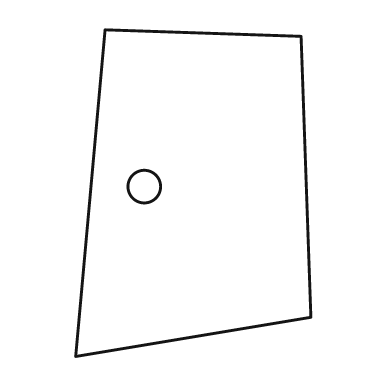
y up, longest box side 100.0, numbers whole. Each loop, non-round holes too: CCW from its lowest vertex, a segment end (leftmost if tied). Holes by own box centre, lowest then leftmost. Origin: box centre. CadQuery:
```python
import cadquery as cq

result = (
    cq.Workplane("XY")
    .moveTo(-36.0, -50.0)
    .lineTo(36.0, -38.0)
    .lineTo(33.0, 48.0)
    .lineTo(-27.0, 50.0)
    .close()
    .moveTo(-15.0, 2.0)
    .circle(5.0)
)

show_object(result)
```